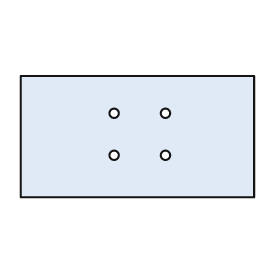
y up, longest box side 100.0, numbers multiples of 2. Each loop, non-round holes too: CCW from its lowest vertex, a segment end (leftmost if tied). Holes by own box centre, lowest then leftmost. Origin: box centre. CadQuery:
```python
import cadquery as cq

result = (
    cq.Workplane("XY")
    .moveTo(-50.0, -26.0)
    .lineTo(50.0, -26.0)
    .lineTo(50.0, 26.0)
    .lineTo(-50.0, 26.0)
    .close()
    .moveTo(-10.0, -8.0)
    .circle(2.0)
    .moveTo(12.0, -8.0)
    .circle(2.0)
    .moveTo(-10.0, 10.0)
    .circle(2.0)
    .moveTo(12.0, 10.0)
    .circle(2.0)
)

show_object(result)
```